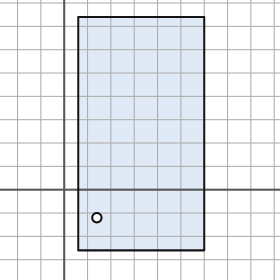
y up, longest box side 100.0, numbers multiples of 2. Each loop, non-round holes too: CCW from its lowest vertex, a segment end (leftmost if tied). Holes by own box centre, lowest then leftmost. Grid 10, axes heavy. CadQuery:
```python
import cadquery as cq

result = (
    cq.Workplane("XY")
    .moveTo(6.0, -26.0)
    .lineTo(60.0, -26.0)
    .lineTo(60.0, 74.0)
    .lineTo(6.0, 74.0)
    .close()
    .moveTo(14.0, -12.0)
    .circle(2.0)
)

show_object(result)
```